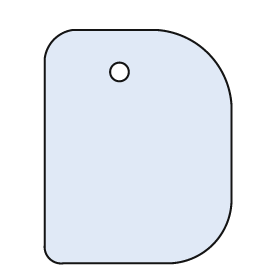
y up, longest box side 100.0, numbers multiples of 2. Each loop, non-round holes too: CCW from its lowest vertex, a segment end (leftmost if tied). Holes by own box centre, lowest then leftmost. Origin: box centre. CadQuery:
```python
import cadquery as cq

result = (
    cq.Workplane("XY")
    .moveTo(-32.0, -50.0)
    .lineTo(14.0, -50.0)
    .threePointArc((32.0, -42.0), (40.0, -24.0))
    .lineTo(40.0, 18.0)
    .threePointArc((30.0, 40.0), (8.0, 50.0))
    .lineTo(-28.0, 50.0)
    .threePointArc((-36.0, 46.0), (-40.0, 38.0))
    .lineTo(-40.0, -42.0)
    .threePointArc((-38.0, -48.0), (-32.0, -50.0))
    .close()
    .moveTo(-8.0, 32.0)
    .circle(4.0)
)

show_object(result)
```